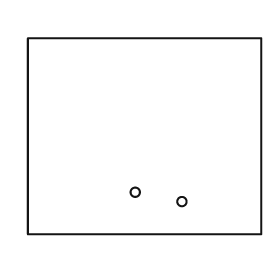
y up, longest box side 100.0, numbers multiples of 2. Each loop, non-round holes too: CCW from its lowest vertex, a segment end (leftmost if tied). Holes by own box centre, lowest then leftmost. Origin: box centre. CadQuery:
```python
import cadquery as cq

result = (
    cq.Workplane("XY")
    .moveTo(-50.0, -42.0)
    .lineTo(50.0, -42.0)
    .lineTo(50.0, 42.0)
    .lineTo(-50.0, 42.0)
    .close()
    .moveTo(16.0, -28.0)
    .circle(2.0)
    .moveTo(-4.0, -24.0)
    .circle(2.0)
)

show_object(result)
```